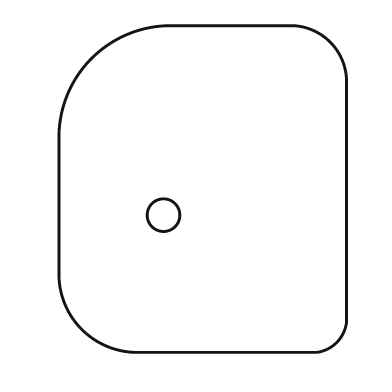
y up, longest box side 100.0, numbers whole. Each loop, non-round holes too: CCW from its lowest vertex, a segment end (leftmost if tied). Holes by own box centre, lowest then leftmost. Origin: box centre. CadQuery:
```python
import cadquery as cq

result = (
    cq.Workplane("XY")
    .moveTo(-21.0, -50.0)
    .lineTo(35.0, -50.0)
    .threePointArc((41.0, -47.0), (44.0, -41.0))
    .lineTo(44.0, 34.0)
    .threePointArc((39.0, 45.0), (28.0, 50.0))
    .lineTo(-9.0, 50.0)
    .threePointArc((-34.0, 40.0), (-44.0, 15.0))
    .lineTo(-44.0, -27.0)
    .threePointArc((-37.0, -43.0), (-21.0, -50.0))
    .close()
    .moveTo(-12.0, -8.0)
    .circle(5.0)
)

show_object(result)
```